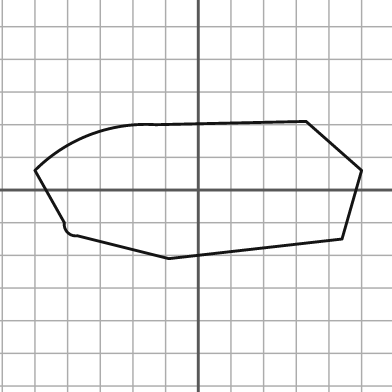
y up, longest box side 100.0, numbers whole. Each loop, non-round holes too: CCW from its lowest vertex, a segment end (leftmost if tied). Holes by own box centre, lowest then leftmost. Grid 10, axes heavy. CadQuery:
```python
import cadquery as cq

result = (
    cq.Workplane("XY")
    .moveTo(-9.0, -21.0)
    .lineTo(44.0, -15.0)
    .lineTo(50.0, 6.0)
    .lineTo(33.0, 21.0)
    .lineTo(-13.0, 20.0)
    .threePointArc((-33.0, 17.0), (-50.0, 6.0))
    .lineTo(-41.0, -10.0)
    .threePointArc((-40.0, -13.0), (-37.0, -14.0))
    .close()
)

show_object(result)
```